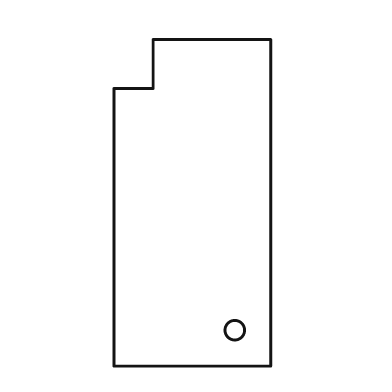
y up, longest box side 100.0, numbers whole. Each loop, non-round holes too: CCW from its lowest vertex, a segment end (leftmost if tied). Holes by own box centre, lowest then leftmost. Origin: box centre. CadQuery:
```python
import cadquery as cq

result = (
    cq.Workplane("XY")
    .moveTo(-24.0, -50.0)
    .lineTo(24.0, -50.0)
    .lineTo(24.0, 50.0)
    .lineTo(-12.0, 50.0)
    .lineTo(-12.0, 35.0)
    .lineTo(-24.0, 35.0)
    .close()
    .moveTo(13.0, -39.0)
    .circle(3.0)
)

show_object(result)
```